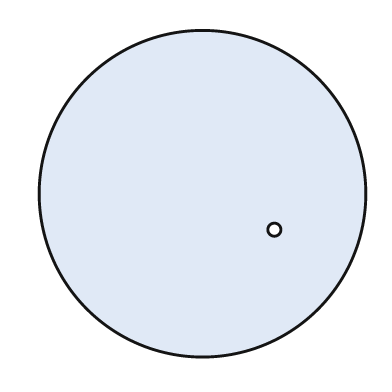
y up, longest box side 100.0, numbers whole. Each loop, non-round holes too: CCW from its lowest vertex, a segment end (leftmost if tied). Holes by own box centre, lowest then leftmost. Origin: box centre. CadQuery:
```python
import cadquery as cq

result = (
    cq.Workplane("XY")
    .moveTo(0.0, 0.0)
    .circle(50.0)
    .moveTo(22.0, -11.0)
    .circle(2.0)
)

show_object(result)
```